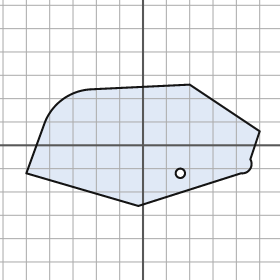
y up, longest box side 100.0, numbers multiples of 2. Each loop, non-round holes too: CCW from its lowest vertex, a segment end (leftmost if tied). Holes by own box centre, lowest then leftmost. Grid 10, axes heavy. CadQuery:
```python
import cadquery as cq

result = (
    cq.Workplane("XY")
    .moveTo(-2.0, -26.0)
    .lineTo(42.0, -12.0)
    .threePointArc((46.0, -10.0), (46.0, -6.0))
    .lineTo(50.0, 6.0)
    .lineTo(20.0, 26.0)
    .lineTo(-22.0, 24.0)
    .threePointArc((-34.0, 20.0), (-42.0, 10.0))
    .lineTo(-50.0, -12.0)
    .close()
    .moveTo(16.0, -12.0)
    .circle(2.0)
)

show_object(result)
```